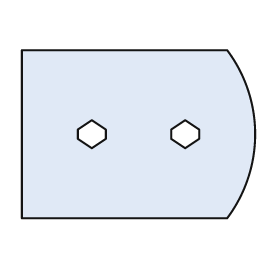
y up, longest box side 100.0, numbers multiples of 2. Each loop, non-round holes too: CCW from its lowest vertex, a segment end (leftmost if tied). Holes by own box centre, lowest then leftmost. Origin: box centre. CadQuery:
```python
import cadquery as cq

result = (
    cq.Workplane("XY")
    .moveTo(-50.0, -36.0)
    .lineTo(38.0, -36.0)
    .threePointArc((50.0, 0.0), (38.0, 36.0))
    .lineTo(-50.0, 36.0)
    .close()
    .moveTo(-20.0, -6.0)
    .lineTo(-14.0, -2.0)
    .lineTo(-14.0, 2.0)
    .lineTo(-20.0, 6.0)
    .lineTo(-26.0, 2.0)
    .lineTo(-26.0, -2.0)
    .close()
    .moveTo(20.0, -6.0)
    .lineTo(26.0, -2.0)
    .lineTo(26.0, 2.0)
    .lineTo(20.0, 6.0)
    .lineTo(14.0, 2.0)
    .lineTo(14.0, -2.0)
    .close()
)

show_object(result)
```